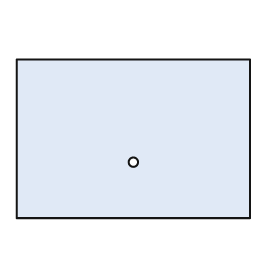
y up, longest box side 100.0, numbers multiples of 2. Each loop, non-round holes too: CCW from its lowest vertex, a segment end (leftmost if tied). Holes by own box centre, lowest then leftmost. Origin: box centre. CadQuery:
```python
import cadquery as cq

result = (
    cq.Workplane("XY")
    .moveTo(-50.0, -34.0)
    .lineTo(50.0, -34.0)
    .lineTo(50.0, 34.0)
    .lineTo(-50.0, 34.0)
    .close()
    .moveTo(0.0, -10.0)
    .circle(2.0)
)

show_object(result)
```